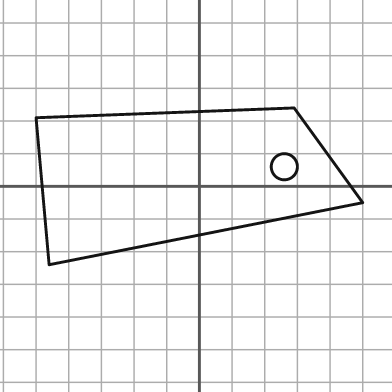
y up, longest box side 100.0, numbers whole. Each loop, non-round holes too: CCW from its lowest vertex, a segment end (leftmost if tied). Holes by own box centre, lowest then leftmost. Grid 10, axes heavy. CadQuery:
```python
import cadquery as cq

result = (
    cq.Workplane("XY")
    .moveTo(-46.0, -24.0)
    .lineTo(50.0, -5.0)
    .lineTo(29.0, 24.0)
    .lineTo(-50.0, 21.0)
    .close()
    .moveTo(26.0, 6.0)
    .circle(4.0)
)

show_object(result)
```